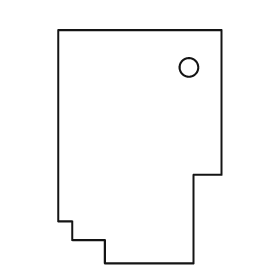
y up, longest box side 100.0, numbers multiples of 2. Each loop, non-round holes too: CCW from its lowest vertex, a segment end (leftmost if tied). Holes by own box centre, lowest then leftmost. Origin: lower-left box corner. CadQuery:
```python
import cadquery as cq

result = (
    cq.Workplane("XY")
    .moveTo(20.0, 0.0)
    .lineTo(58.0, 0.0)
    .lineTo(58.0, 38.0)
    .lineTo(70.0, 38.0)
    .lineTo(70.0, 100.0)
    .lineTo(0.0, 100.0)
    .lineTo(0.0, 18.0)
    .lineTo(6.0, 18.0)
    .lineTo(6.0, 10.0)
    .lineTo(20.0, 10.0)
    .close()
    .moveTo(56.0, 84.0)
    .circle(4.0)
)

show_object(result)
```